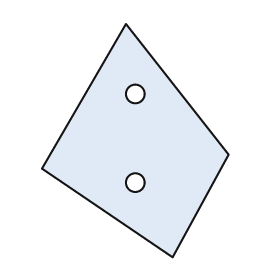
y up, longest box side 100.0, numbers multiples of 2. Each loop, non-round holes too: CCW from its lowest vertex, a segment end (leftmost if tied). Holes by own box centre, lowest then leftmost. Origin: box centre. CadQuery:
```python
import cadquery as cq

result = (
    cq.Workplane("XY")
    .moveTo(16.0, -50.0)
    .lineTo(40.0, -6.0)
    .lineTo(-4.0, 50.0)
    .lineTo(-40.0, -12.0)
    .close()
    .moveTo(0.0, -18.0)
    .circle(4.0)
    .moveTo(0.0, 20.0)
    .circle(4.0)
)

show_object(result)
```